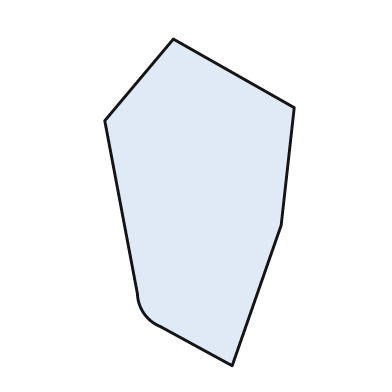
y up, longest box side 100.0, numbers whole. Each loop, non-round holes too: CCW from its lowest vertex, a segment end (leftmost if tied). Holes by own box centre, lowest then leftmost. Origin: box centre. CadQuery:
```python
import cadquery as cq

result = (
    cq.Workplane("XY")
    .moveTo(10.0, -50.0)
    .lineTo(25.0, -7.0)
    .lineTo(29.0, 29.0)
    .lineTo(-8.0, 50.0)
    .lineTo(-29.0, 25.0)
    .lineTo(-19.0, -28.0)
    .threePointArc((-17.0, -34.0), (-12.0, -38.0))
    .close()
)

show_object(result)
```